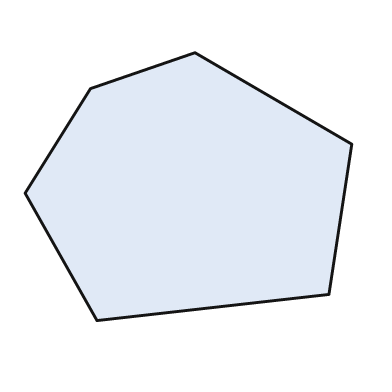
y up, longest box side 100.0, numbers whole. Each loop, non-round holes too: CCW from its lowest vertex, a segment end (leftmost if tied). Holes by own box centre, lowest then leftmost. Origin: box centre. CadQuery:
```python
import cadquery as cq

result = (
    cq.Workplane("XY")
    .moveTo(-28.0, -41.0)
    .lineTo(43.0, -33.0)
    .lineTo(50.0, 13.0)
    .lineTo(2.0, 41.0)
    .lineTo(-30.0, 30.0)
    .lineTo(-50.0, -2.0)
    .close()
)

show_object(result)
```